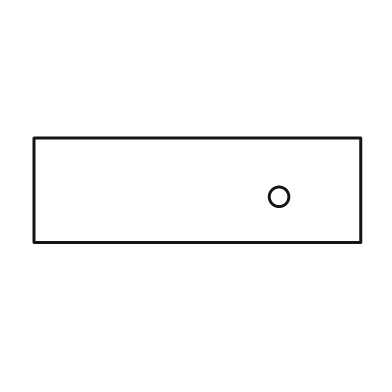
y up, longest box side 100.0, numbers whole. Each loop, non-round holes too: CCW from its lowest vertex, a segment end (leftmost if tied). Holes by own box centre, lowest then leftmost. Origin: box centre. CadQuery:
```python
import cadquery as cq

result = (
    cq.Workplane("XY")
    .moveTo(-50.0, -16.0)
    .lineTo(50.0, -16.0)
    .lineTo(50.0, 16.0)
    .lineTo(-50.0, 16.0)
    .close()
    .moveTo(25.0, -2.0)
    .circle(3.0)
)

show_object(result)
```